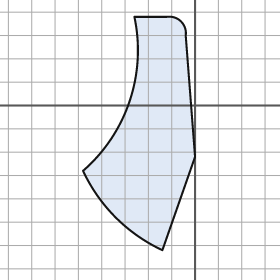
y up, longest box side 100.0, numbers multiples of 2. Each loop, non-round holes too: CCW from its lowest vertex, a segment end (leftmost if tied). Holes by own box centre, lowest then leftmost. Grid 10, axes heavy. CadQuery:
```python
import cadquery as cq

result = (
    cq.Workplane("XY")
    .moveTo(-14.0, -62.0)
    .lineTo(0.0, -22.0)
    .lineTo(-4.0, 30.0)
    .threePointArc((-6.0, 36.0), (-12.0, 38.0))
    .lineTo(-26.0, 38.0)
    .threePointArc((-28.0, 2.0), (-48.0, -28.0))
    .threePointArc((-34.0, -48.0), (-14.0, -62.0))
    .close()
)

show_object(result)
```